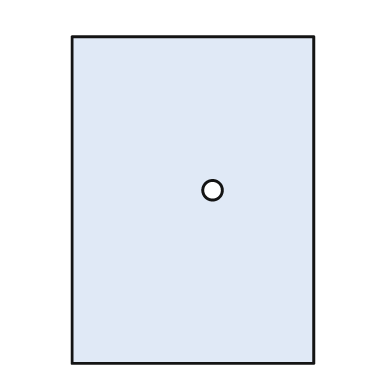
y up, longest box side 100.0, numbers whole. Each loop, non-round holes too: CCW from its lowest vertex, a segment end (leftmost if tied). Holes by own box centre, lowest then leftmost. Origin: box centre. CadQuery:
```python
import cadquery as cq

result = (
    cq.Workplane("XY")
    .moveTo(-37.0, -50.0)
    .lineTo(37.0, -50.0)
    .lineTo(37.0, 50.0)
    .lineTo(-37.0, 50.0)
    .close()
    .moveTo(6.0, 3.0)
    .circle(3.0)
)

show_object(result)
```